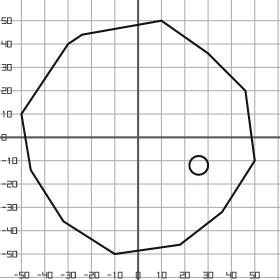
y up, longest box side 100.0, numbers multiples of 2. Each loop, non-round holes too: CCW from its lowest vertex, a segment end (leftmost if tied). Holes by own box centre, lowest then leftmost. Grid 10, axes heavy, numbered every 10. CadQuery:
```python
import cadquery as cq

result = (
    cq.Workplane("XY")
    .moveTo(-10.0, -50.0)
    .lineTo(18.0, -46.0)
    .lineTo(36.0, -32.0)
    .lineTo(50.0, -10.0)
    .lineTo(46.0, 20.0)
    .lineTo(30.0, 36.0)
    .lineTo(10.0, 50.0)
    .lineTo(-24.0, 44.0)
    .lineTo(-30.0, 40.0)
    .lineTo(-50.0, 10.0)
    .lineTo(-46.0, -14.0)
    .lineTo(-32.0, -36.0)
    .close()
    .moveTo(26.0, -12.0)
    .circle(4.0)
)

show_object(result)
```